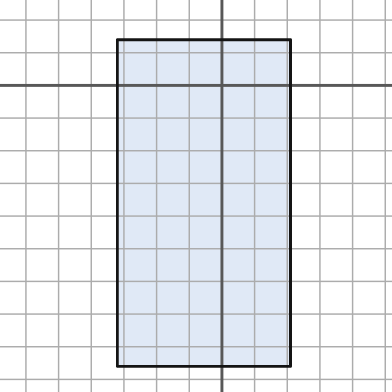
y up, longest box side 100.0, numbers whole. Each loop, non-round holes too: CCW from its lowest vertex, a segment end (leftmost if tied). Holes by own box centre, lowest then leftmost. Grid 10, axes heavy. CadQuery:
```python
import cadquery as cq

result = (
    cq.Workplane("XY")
    .moveTo(-32.0, -86.0)
    .lineTo(21.0, -86.0)
    .lineTo(21.0, 14.0)
    .lineTo(-32.0, 14.0)
    .close()
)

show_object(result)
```